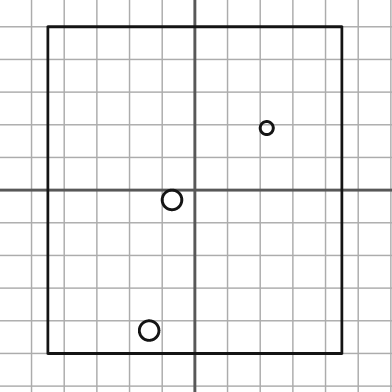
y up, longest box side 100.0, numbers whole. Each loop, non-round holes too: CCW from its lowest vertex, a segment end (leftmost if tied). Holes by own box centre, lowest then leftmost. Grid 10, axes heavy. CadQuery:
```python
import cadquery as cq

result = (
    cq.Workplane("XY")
    .moveTo(-45.0, -50.0)
    .lineTo(45.0, -50.0)
    .lineTo(45.0, 50.0)
    .lineTo(-45.0, 50.0)
    .close()
    .moveTo(-14.0, -43.0)
    .circle(3.0)
    .moveTo(-7.0, -3.0)
    .circle(3.0)
    .moveTo(22.0, 19.0)
    .circle(2.0)
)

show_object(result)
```